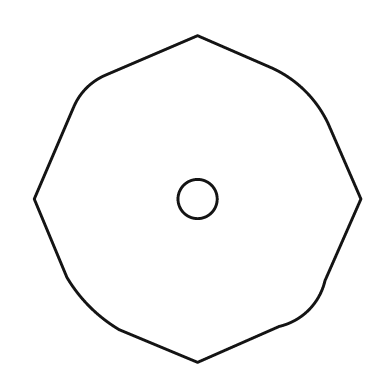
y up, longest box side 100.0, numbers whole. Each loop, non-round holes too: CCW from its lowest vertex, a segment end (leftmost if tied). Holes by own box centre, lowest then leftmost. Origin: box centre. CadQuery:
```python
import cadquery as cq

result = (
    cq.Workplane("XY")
    .moveTo(0.0, -50.0)
    .lineTo(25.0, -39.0)
    .threePointArc((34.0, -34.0), (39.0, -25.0))
    .lineTo(50.0, 0.0)
    .lineTo(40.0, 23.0)
    .threePointArc((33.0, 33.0), (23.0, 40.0))
    .lineTo(0.0, 50.0)
    .lineTo(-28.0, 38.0)
    .threePointArc((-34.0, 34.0), (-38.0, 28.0))
    .lineTo(-50.0, 0.0)
    .lineTo(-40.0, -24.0)
    .threePointArc((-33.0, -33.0), (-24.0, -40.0))
    .close()
    .moveTo(0.0, 0.0)
    .circle(6.0)
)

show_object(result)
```